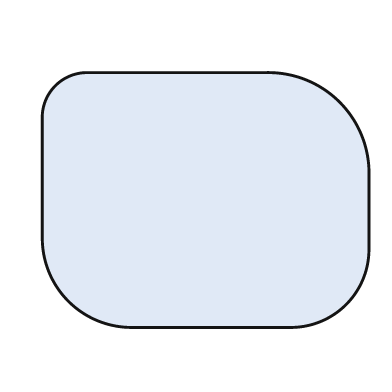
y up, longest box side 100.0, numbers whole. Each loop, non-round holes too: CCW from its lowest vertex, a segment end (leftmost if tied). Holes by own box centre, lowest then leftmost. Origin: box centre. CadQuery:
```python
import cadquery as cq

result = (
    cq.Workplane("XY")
    .moveTo(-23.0, -39.0)
    .lineTo(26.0, -39.0)
    .threePointArc((43.0, -32.0), (50.0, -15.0))
    .lineTo(50.0, 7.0)
    .threePointArc((41.0, 30.0), (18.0, 39.0))
    .lineTo(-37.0, 39.0)
    .threePointArc((-46.0, 35.0), (-50.0, 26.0))
    .lineTo(-50.0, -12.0)
    .threePointArc((-42.0, -31.0), (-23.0, -39.0))
    .close()
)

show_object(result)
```